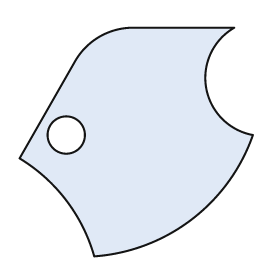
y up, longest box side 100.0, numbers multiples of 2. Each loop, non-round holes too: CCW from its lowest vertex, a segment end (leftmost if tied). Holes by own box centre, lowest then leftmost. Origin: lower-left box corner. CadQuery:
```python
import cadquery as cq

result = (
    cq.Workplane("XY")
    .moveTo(32.0, 0.0)
    .threePointArc((74.0, 16.0), (100.0, 52.0))
    .threePointArc((80.0, 72.0), (92.0, 98.0))
    .lineTo(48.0, 98.0)
    .threePointArc((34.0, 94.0), (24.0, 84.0))
    .lineTo(0.0, 42.0)
    .threePointArc((20.0, 24.0), (32.0, 0.0))
    .close()
    .moveTo(20.0, 52.0)
    .circle(8.0)
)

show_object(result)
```